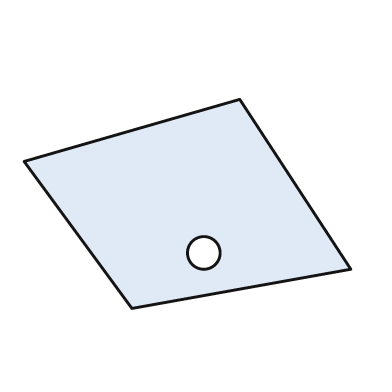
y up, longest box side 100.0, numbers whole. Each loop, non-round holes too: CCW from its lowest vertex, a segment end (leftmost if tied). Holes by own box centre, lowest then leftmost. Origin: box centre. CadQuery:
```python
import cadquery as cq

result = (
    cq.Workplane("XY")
    .moveTo(-17.0, -32.0)
    .lineTo(50.0, -20.0)
    .lineTo(16.0, 32.0)
    .lineTo(-50.0, 13.0)
    .close()
    .moveTo(5.0, -15.0)
    .circle(5.0)
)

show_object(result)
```